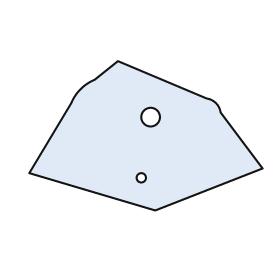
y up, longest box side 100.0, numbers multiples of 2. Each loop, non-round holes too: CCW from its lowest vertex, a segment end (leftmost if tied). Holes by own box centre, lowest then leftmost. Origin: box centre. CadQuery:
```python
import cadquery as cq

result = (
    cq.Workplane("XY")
    .moveTo(4.0, -32.0)
    .lineTo(50.0, -14.0)
    .lineTo(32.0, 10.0)
    .threePointArc((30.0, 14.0), (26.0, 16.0))
    .lineTo(-12.0, 32.0)
    .lineTo(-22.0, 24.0)
    .threePointArc((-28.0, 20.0), (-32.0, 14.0))
    .lineTo(-50.0, -16.0)
    .close()
    .moveTo(-2.0, -18.0)
    .circle(2.0)
    .moveTo(2.0, 8.0)
    .circle(4.0)
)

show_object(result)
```